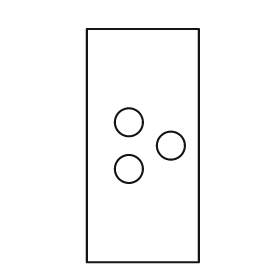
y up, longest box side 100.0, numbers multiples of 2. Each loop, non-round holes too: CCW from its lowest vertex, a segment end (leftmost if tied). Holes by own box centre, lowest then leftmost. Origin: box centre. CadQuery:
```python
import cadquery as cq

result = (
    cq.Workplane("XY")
    .moveTo(-24.0, -50.0)
    .lineTo(24.0, -50.0)
    .lineTo(24.0, 50.0)
    .lineTo(-24.0, 50.0)
    .close()
    .moveTo(-6.0, -10.0)
    .circle(6.0)
    .moveTo(12.0, 0.0)
    .circle(6.0)
    .moveTo(-6.0, 10.0)
    .circle(6.0)
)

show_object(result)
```